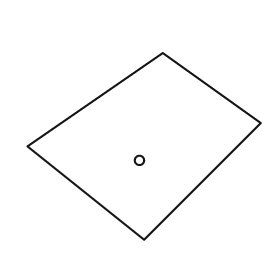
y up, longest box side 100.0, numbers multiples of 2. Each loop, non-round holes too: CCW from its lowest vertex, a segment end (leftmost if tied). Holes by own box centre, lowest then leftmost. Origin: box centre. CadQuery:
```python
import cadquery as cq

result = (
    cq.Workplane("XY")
    .moveTo(0.0, -40.0)
    .lineTo(50.0, 10.0)
    .lineTo(8.0, 40.0)
    .lineTo(-50.0, 0.0)
    .close()
    .moveTo(-2.0, -6.0)
    .circle(2.0)
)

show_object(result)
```